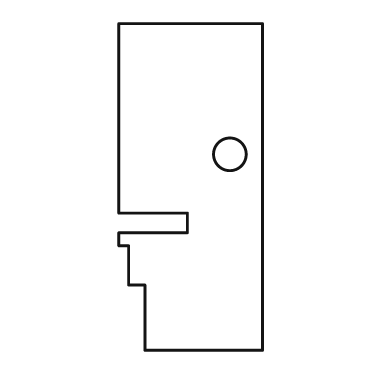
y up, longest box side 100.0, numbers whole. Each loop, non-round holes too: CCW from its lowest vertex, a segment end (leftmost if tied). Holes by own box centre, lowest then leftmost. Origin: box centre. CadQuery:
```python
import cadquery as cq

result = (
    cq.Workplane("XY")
    .moveTo(-14.0, -50.0)
    .lineTo(22.0, -50.0)
    .lineTo(22.0, 50.0)
    .lineTo(-22.0, 50.0)
    .lineTo(-22.0, -8.0)
    .lineTo(-1.0, -8.0)
    .lineTo(-1.0, -14.0)
    .lineTo(-22.0, -14.0)
    .lineTo(-22.0, -18.0)
    .lineTo(-19.0, -18.0)
    .lineTo(-19.0, -30.0)
    .lineTo(-14.0, -30.0)
    .close()
    .moveTo(12.0, 10.0)
    .circle(5.0)
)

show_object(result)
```